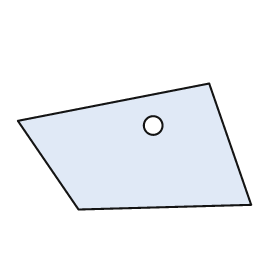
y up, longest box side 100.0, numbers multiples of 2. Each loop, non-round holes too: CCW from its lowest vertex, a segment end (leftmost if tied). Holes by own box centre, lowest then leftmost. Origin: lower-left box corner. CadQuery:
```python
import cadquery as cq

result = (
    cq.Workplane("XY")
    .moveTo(26.0, 0.0)
    .lineTo(100.0, 2.0)
    .lineTo(82.0, 54.0)
    .lineTo(0.0, 38.0)
    .close()
    .moveTo(58.0, 36.0)
    .circle(4.0)
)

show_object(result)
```